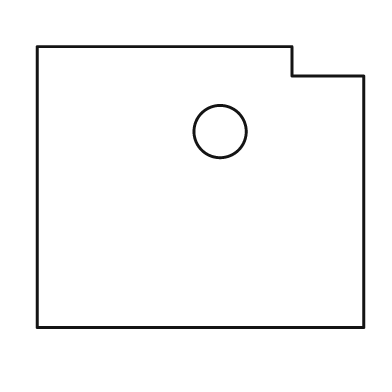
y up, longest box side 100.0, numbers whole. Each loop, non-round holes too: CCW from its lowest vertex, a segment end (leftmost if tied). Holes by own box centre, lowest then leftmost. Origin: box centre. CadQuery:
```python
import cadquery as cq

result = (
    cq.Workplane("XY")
    .moveTo(-50.0, -43.0)
    .lineTo(50.0, -43.0)
    .lineTo(50.0, 34.0)
    .lineTo(28.0, 34.0)
    .lineTo(28.0, 43.0)
    .lineTo(-50.0, 43.0)
    .close()
    .moveTo(6.0, 17.0)
    .circle(8.0)
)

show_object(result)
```